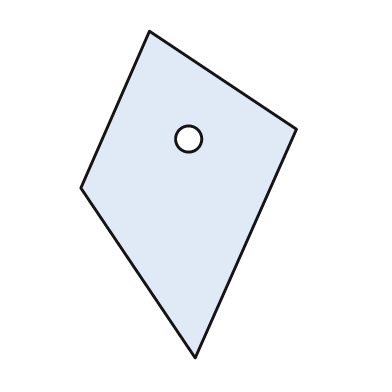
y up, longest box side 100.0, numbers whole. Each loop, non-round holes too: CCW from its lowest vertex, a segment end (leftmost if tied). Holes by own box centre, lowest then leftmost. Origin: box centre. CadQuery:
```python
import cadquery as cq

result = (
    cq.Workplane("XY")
    .moveTo(2.0, -50.0)
    .lineTo(33.0, 20.0)
    .lineTo(-12.0, 50.0)
    .lineTo(-33.0, 2.0)
    .close()
    .moveTo(0.0, 17.0)
    .circle(4.0)
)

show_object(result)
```